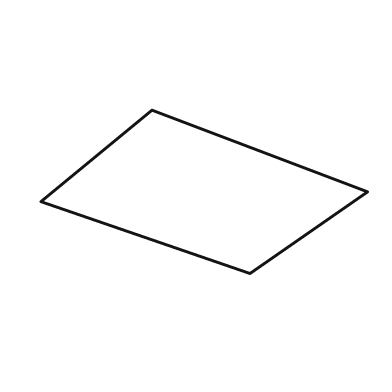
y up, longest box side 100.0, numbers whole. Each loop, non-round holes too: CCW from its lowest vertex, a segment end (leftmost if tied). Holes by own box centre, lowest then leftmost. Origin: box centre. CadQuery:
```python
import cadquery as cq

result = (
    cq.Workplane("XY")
    .moveTo(14.0, -25.0)
    .lineTo(50.0, 0.0)
    .lineTo(-16.0, 25.0)
    .lineTo(-50.0, -3.0)
    .close()
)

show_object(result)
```